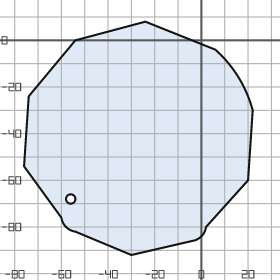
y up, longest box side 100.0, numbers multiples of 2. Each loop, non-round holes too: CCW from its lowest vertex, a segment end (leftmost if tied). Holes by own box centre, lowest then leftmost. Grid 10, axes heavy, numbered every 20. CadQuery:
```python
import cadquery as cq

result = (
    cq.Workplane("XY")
    .moveTo(-30.0, -92.0)
    .lineTo(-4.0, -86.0)
    .threePointArc((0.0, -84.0), (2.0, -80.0))
    .lineTo(20.0, -60.0)
    .lineTo(22.0, -30.0)
    .threePointArc((16.0, -16.0), (6.0, -4.0))
    .lineTo(-24.0, 8.0)
    .lineTo(-54.0, 0.0)
    .lineTo(-74.0, -24.0)
    .lineTo(-76.0, -54.0)
    .lineTo(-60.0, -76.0)
    .threePointArc((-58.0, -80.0), (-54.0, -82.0))
    .close()
    .moveTo(-56.0, -68.0)
    .circle(2.0)
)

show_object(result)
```